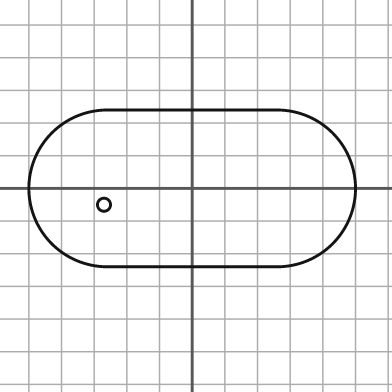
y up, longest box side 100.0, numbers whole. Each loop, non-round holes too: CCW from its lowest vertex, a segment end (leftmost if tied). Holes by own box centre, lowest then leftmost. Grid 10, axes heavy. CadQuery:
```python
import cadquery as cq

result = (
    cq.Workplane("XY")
    .moveTo(-26.0, -24.0)
    .lineTo(26.0, -24.0)
    .threePointArc((50.0, 0.0), (26.0, 24.0))
    .lineTo(-26.0, 24.0)
    .threePointArc((-50.0, 0.0), (-26.0, -24.0))
    .close()
    .moveTo(-27.0, -5.0)
    .circle(2.0)
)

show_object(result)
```